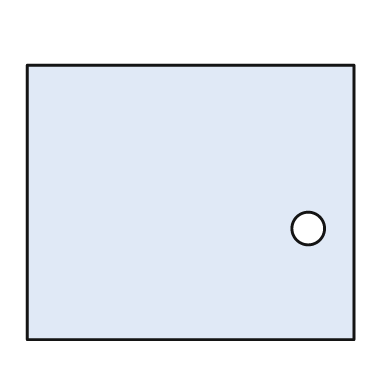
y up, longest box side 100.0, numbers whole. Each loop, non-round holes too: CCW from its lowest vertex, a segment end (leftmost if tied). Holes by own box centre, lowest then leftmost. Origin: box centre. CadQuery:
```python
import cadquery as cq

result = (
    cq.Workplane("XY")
    .moveTo(-50.0, -42.0)
    .lineTo(50.0, -42.0)
    .lineTo(50.0, 42.0)
    .lineTo(-50.0, 42.0)
    .close()
    .moveTo(36.0, -8.0)
    .circle(5.0)
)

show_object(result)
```